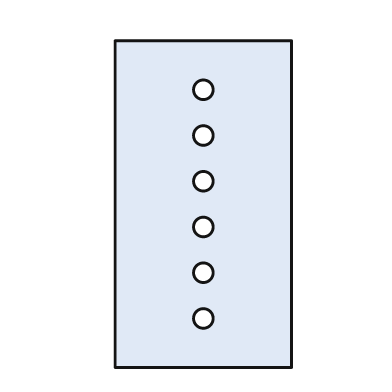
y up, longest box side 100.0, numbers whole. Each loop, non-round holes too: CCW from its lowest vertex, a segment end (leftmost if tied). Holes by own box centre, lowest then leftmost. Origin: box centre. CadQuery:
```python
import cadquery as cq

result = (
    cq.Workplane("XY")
    .moveTo(-27.0, -50.0)
    .lineTo(27.0, -50.0)
    .lineTo(27.0, 50.0)
    .lineTo(-27.0, 50.0)
    .close()
    .moveTo(0.0, -35.0)
    .circle(3.0)
    .moveTo(0.0, -21.0)
    .circle(3.0)
    .moveTo(0.0, -7.0)
    .circle(3.0)
    .moveTo(0.0, 7.0)
    .circle(3.0)
    .moveTo(0.0, 21.0)
    .circle(3.0)
    .moveTo(0.0, 35.0)
    .circle(3.0)
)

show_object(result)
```